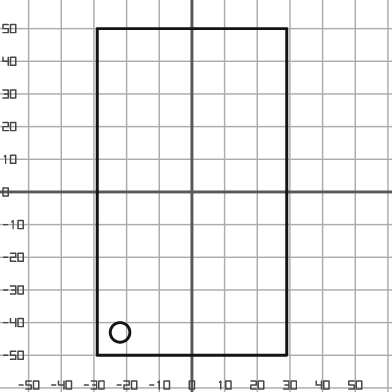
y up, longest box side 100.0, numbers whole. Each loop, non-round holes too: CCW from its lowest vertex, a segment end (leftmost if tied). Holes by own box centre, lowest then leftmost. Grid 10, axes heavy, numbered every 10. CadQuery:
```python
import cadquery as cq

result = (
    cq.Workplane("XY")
    .moveTo(-29.0, -50.0)
    .lineTo(29.0, -50.0)
    .lineTo(29.0, 50.0)
    .lineTo(-29.0, 50.0)
    .close()
    .moveTo(-22.0, -43.0)
    .circle(3.0)
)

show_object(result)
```